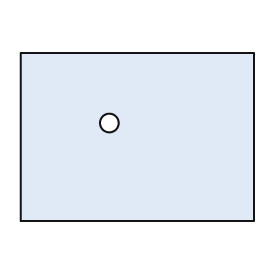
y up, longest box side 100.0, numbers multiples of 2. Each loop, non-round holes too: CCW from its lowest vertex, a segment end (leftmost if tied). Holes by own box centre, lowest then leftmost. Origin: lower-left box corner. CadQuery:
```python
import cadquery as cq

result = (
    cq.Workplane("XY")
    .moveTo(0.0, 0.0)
    .lineTo(100.0, 0.0)
    .lineTo(100.0, 72.0)
    .lineTo(0.0, 72.0)
    .close()
    .moveTo(38.0, 42.0)
    .circle(4.0)
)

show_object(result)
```